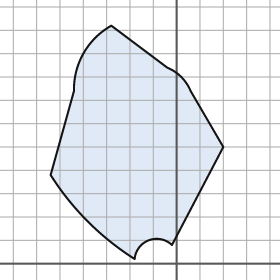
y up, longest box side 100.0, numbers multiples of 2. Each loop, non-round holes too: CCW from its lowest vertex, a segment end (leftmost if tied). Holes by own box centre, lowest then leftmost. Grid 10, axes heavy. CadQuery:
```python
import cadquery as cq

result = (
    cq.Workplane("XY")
    .moveTo(-18.0, 2.0)
    .threePointArc((-12.0, 10.0), (-2.0, 8.0))
    .lineTo(20.0, 50.0)
    .lineTo(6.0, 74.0)
    .threePointArc((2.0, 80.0), (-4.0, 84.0))
    .lineTo(-28.0, 102.0)
    .threePointArc((-40.0, 90.0), (-44.0, 74.0))
    .lineTo(-54.0, 38.0)
    .threePointArc((-38.0, 18.0), (-18.0, 2.0))
    .close()
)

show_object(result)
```